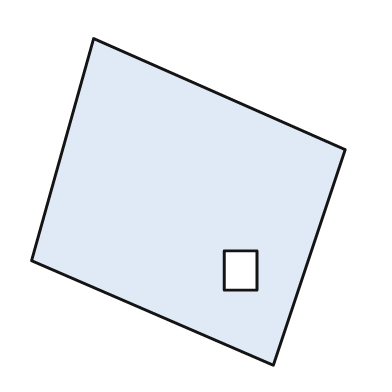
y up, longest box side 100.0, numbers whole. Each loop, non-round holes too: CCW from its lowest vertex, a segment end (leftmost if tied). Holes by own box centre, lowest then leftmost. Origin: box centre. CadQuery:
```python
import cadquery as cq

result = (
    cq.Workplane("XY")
    .moveTo(26.0, -50.0)
    .lineTo(48.0, 16.0)
    .lineTo(-29.0, 50.0)
    .lineTo(-48.0, -18.0)
    .close()
    .moveTo(11.0, -27.0)
    .lineTo(21.0, -27.0)
    .lineTo(21.0, -15.0)
    .lineTo(11.0, -15.0)
    .close()
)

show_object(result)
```